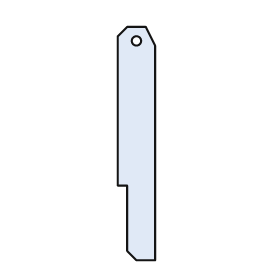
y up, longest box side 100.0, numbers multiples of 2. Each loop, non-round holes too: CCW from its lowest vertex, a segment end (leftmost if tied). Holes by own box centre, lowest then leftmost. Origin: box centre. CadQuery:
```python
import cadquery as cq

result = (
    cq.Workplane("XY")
    .moveTo(0.0, -50.0)
    .lineTo(8.0, -50.0)
    .lineTo(8.0, 42.0)
    .lineTo(4.0, 50.0)
    .lineTo(-4.0, 50.0)
    .lineTo(-8.0, 46.0)
    .lineTo(-8.0, -18.0)
    .lineTo(-4.0, -18.0)
    .lineTo(-4.0, -46.0)
    .close()
    .moveTo(0.0, 44.0)
    .circle(2.0)
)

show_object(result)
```